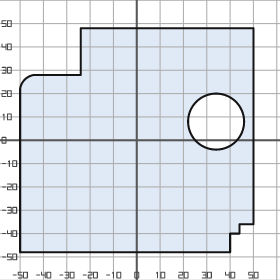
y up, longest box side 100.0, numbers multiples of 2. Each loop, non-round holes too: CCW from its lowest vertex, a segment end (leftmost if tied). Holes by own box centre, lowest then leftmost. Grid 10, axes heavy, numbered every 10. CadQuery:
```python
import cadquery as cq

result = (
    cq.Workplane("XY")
    .moveTo(-50.0, -48.0)
    .lineTo(40.0, -48.0)
    .lineTo(40.0, -40.0)
    .lineTo(44.0, -40.0)
    .lineTo(44.0, -36.0)
    .lineTo(50.0, -36.0)
    .lineTo(50.0, 48.0)
    .lineTo(-24.0, 48.0)
    .lineTo(-24.0, 28.0)
    .lineTo(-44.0, 28.0)
    .threePointArc((-48.0, 26.0), (-50.0, 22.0))
    .close()
    .moveTo(34.0, 8.0)
    .circle(12.0)
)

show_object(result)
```